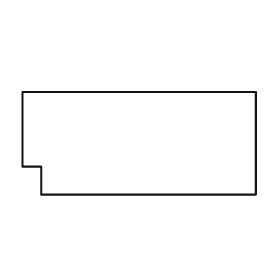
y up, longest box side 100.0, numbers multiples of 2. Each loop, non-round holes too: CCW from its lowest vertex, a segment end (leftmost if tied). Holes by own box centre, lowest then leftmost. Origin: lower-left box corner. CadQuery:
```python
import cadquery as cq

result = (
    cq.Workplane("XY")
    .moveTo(8.0, 0.0)
    .lineTo(100.0, 0.0)
    .lineTo(100.0, 44.0)
    .lineTo(0.0, 44.0)
    .lineTo(0.0, 12.0)
    .lineTo(8.0, 12.0)
    .close()
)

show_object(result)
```